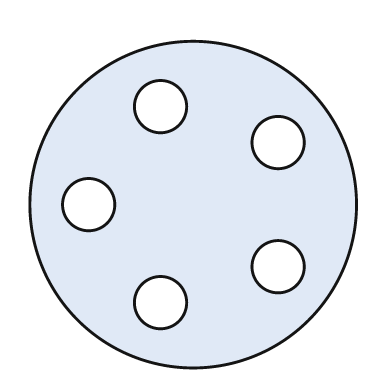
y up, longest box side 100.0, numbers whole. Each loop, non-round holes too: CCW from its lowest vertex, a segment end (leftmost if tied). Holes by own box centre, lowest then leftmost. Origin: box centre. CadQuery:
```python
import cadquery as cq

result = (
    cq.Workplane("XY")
    .moveTo(0.0, 0.0)
    .circle(50.0)
    .moveTo(-10.0, -30.0)
    .circle(8.0)
    .moveTo(26.0, -19.0)
    .circle(8.0)
    .moveTo(-32.0, 0.0)
    .circle(8.0)
    .moveTo(26.0, 19.0)
    .circle(8.0)
    .moveTo(-10.0, 30.0)
    .circle(8.0)
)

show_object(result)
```